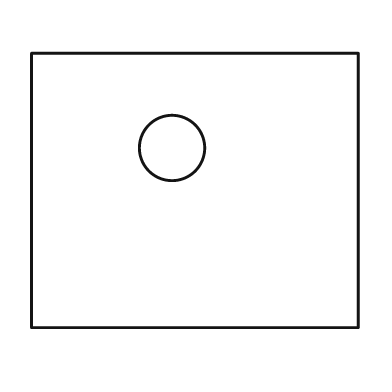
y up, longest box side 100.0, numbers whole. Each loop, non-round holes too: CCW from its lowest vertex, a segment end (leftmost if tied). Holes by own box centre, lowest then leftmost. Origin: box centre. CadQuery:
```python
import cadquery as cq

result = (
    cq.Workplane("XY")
    .moveTo(-50.0, -42.0)
    .lineTo(50.0, -42.0)
    .lineTo(50.0, 42.0)
    .lineTo(-50.0, 42.0)
    .close()
    .moveTo(-7.0, 13.0)
    .circle(10.0)
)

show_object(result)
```